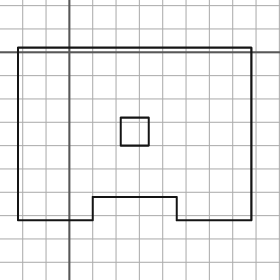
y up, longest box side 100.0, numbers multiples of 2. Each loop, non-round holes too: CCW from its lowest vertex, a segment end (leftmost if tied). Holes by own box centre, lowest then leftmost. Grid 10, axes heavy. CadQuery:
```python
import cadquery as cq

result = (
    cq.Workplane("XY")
    .moveTo(-22.0, -72.0)
    .lineTo(10.0, -72.0)
    .lineTo(10.0, -62.0)
    .lineTo(46.0, -62.0)
    .lineTo(46.0, -72.0)
    .lineTo(78.0, -72.0)
    .lineTo(78.0, 2.0)
    .lineTo(-22.0, 2.0)
    .close()
    .moveTo(22.0, -40.0)
    .lineTo(34.0, -40.0)
    .lineTo(34.0, -28.0)
    .lineTo(22.0, -28.0)
    .close()
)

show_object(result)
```